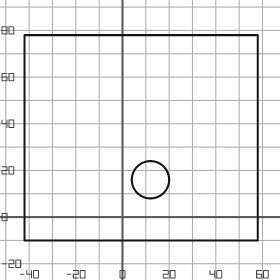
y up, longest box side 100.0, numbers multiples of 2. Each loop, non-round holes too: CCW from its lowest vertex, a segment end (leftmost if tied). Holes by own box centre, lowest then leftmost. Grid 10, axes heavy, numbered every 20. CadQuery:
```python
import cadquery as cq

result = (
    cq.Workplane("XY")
    .moveTo(-42.0, -10.0)
    .lineTo(58.0, -10.0)
    .lineTo(58.0, 78.0)
    .lineTo(-42.0, 78.0)
    .close()
    .moveTo(12.0, 16.0)
    .circle(8.0)
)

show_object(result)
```